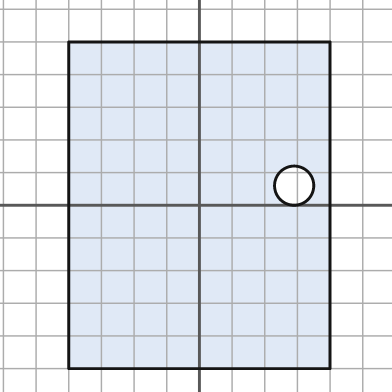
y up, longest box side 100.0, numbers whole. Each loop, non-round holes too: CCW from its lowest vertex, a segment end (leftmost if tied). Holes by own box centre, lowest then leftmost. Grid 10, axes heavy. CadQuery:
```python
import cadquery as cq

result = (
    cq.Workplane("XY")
    .moveTo(-40.0, -50.0)
    .lineTo(40.0, -50.0)
    .lineTo(40.0, 50.0)
    .lineTo(-40.0, 50.0)
    .close()
    .moveTo(29.0, 6.0)
    .circle(6.0)
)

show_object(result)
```